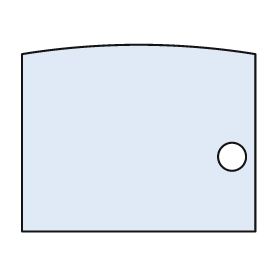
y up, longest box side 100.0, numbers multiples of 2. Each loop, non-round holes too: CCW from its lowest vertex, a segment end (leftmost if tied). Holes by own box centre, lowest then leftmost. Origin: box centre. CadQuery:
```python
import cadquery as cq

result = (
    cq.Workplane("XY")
    .moveTo(-50.0, -40.0)
    .lineTo(50.0, -40.0)
    .lineTo(50.0, 36.0)
    .threePointArc((0.0, 40.0), (-50.0, 36.0))
    .close()
    .moveTo(40.0, -8.0)
    .circle(6.0)
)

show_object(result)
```